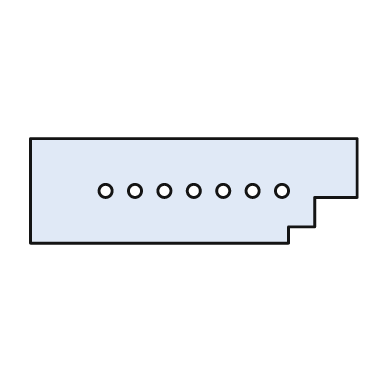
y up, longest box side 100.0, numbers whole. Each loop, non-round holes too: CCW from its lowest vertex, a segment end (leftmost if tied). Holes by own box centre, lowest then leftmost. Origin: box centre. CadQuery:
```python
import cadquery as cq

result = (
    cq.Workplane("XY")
    .moveTo(-50.0, -16.0)
    .lineTo(29.0, -16.0)
    .lineTo(29.0, -11.0)
    .lineTo(37.0, -11.0)
    .lineTo(37.0, -2.0)
    .lineTo(50.0, -2.0)
    .lineTo(50.0, 16.0)
    .lineTo(-50.0, 16.0)
    .close()
    .moveTo(-27.0, 0.0)
    .circle(2.0)
    .moveTo(-18.0, 0.0)
    .circle(2.0)
    .moveTo(-9.0, 0.0)
    .circle(2.0)
    .moveTo(0.0, 0.0)
    .circle(2.0)
    .moveTo(9.0, 0.0)
    .circle(2.0)
    .moveTo(18.0, 0.0)
    .circle(2.0)
    .moveTo(27.0, 0.0)
    .circle(2.0)
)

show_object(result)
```